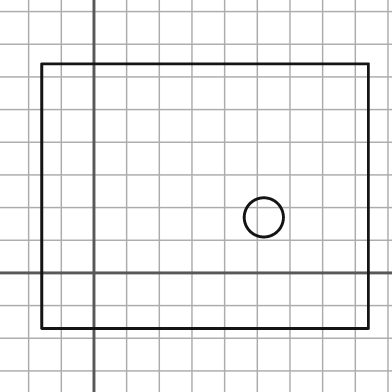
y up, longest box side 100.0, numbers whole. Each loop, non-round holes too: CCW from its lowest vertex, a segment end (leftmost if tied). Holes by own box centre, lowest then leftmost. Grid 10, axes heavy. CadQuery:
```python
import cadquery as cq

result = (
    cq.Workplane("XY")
    .moveTo(-16.0, -17.0)
    .lineTo(84.0, -17.0)
    .lineTo(84.0, 64.0)
    .lineTo(-16.0, 64.0)
    .close()
    .moveTo(52.0, 17.0)
    .circle(6.0)
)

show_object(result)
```